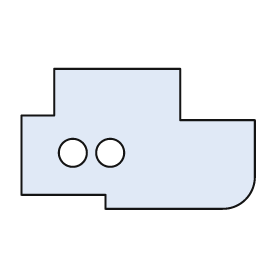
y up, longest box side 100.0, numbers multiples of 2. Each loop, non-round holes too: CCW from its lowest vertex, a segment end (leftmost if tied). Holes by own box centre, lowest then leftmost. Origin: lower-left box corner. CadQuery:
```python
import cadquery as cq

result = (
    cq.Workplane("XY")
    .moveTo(36.0, 0.0)
    .lineTo(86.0, 0.0)
    .threePointArc((96.0, 4.0), (100.0, 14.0))
    .lineTo(100.0, 38.0)
    .lineTo(68.0, 38.0)
    .lineTo(68.0, 60.0)
    .lineTo(14.0, 60.0)
    .lineTo(14.0, 40.0)
    .lineTo(0.0, 40.0)
    .lineTo(0.0, 6.0)
    .lineTo(36.0, 6.0)
    .close()
    .moveTo(22.0, 24.0)
    .circle(6.0)
    .moveTo(38.0, 24.0)
    .circle(6.0)
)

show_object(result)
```